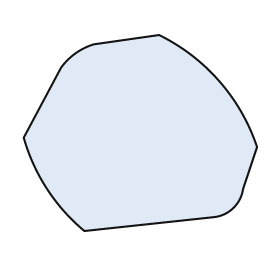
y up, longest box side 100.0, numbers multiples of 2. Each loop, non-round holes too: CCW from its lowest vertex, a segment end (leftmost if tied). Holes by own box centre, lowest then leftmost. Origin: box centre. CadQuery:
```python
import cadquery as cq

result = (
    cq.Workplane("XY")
    .moveTo(-24.0, -42.0)
    .lineTo(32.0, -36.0)
    .threePointArc((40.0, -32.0), (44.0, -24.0))
    .lineTo(50.0, -6.0)
    .threePointArc((34.0, 22.0), (8.0, 42.0))
    .lineTo(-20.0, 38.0)
    .threePointArc((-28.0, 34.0), (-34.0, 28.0))
    .lineTo(-50.0, -2.0)
    .threePointArc((-40.0, -24.0), (-24.0, -42.0))
    .close()
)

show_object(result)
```